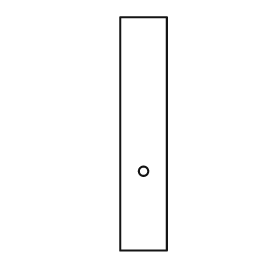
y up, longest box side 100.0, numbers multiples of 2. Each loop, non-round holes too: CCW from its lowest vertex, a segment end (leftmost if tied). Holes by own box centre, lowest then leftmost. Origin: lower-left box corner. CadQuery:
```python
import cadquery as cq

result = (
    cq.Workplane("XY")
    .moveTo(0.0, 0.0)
    .lineTo(20.0, 0.0)
    .lineTo(20.0, 100.0)
    .lineTo(0.0, 100.0)
    .close()
    .moveTo(10.0, 34.0)
    .circle(2.0)
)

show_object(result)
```